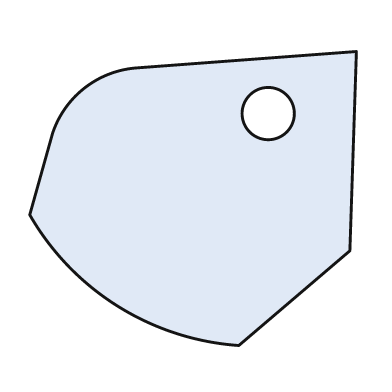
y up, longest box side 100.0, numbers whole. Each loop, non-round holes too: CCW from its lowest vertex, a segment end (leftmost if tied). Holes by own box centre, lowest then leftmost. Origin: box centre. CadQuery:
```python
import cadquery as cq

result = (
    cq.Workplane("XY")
    .moveTo(14.0, -45.0)
    .lineTo(48.0, -16.0)
    .lineTo(50.0, 45.0)
    .lineTo(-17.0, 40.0)
    .threePointArc((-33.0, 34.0), (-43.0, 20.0))
    .lineTo(-50.0, -5.0)
    .threePointArc((-23.0, -33.0), (14.0, -45.0))
    .close()
    .moveTo(23.0, 26.0)
    .circle(8.0)
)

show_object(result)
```